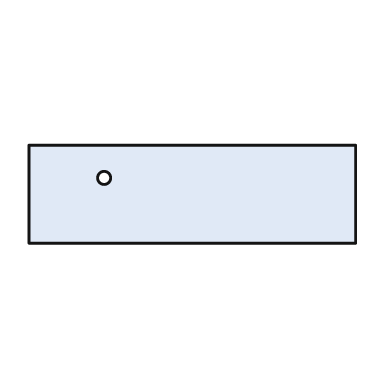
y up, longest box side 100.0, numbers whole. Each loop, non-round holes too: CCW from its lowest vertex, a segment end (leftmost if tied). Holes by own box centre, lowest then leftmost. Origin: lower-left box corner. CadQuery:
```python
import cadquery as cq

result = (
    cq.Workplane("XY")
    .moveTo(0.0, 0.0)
    .lineTo(100.0, 0.0)
    .lineTo(100.0, 30.0)
    .lineTo(0.0, 30.0)
    .close()
    .moveTo(23.0, 20.0)
    .circle(2.0)
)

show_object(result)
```